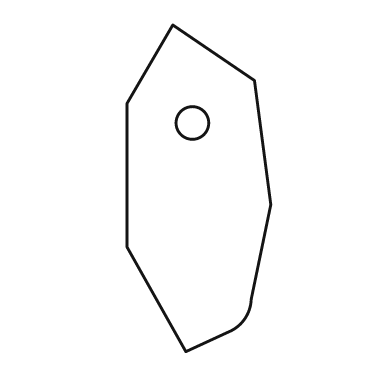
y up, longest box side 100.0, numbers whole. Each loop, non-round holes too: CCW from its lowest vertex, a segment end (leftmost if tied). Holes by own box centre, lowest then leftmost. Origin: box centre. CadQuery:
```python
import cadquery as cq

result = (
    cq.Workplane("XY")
    .moveTo(-4.0, -50.0)
    .lineTo(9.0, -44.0)
    .threePointArc((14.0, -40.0), (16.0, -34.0))
    .lineTo(22.0, -5.0)
    .lineTo(17.0, 33.0)
    .lineTo(-8.0, 50.0)
    .lineTo(-22.0, 26.0)
    .lineTo(-22.0, -18.0)
    .close()
    .moveTo(-2.0, 20.0)
    .circle(5.0)
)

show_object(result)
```